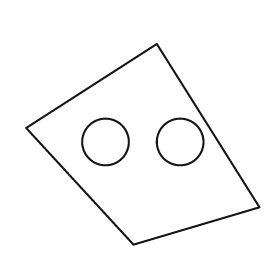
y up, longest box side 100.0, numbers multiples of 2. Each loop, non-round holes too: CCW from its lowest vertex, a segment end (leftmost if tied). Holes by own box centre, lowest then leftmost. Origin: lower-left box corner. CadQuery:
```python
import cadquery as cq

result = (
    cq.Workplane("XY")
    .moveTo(46.0, 0.0)
    .lineTo(100.0, 16.0)
    .lineTo(56.0, 86.0)
    .lineTo(0.0, 50.0)
    .close()
    .moveTo(34.0, 44.0)
    .circle(10.0)
    .moveTo(66.0, 44.0)
    .circle(10.0)
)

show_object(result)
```